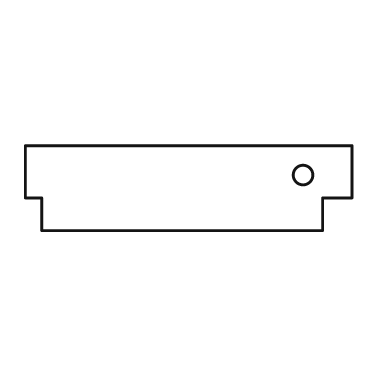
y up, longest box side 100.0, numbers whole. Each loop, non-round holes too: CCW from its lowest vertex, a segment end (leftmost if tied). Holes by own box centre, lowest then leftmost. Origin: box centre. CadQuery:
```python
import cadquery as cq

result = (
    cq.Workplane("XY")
    .moveTo(-45.0, -13.0)
    .lineTo(41.0, -13.0)
    .lineTo(41.0, -3.0)
    .lineTo(50.0, -3.0)
    .lineTo(50.0, 13.0)
    .lineTo(-50.0, 13.0)
    .lineTo(-50.0, -3.0)
    .lineTo(-45.0, -3.0)
    .close()
    .moveTo(35.0, 4.0)
    .circle(3.0)
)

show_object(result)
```